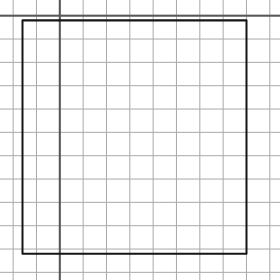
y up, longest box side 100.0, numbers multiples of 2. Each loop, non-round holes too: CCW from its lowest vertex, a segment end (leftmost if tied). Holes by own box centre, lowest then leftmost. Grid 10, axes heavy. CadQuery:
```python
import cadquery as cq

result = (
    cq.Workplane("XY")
    .moveTo(-16.0, -102.0)
    .lineTo(80.0, -102.0)
    .lineTo(80.0, -2.0)
    .lineTo(-16.0, -2.0)
    .close()
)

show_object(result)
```